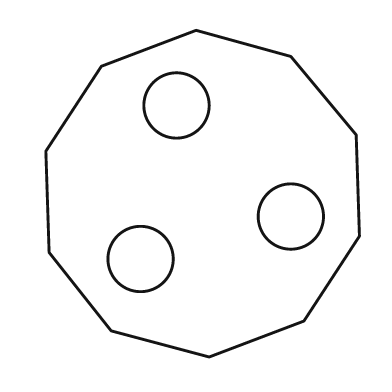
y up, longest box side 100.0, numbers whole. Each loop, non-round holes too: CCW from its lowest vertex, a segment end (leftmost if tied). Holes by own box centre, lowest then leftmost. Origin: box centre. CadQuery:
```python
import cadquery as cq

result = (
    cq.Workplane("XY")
    .moveTo(2.0, -50.0)
    .lineTo(31.0, -39.0)
    .lineTo(48.0, -13.0)
    .lineTo(47.0, 18.0)
    .lineTo(27.0, 42.0)
    .lineTo(-2.0, 50.0)
    .lineTo(-31.0, 39.0)
    .lineTo(-48.0, 13.0)
    .lineTo(-47.0, -18.0)
    .lineTo(-28.0, -42.0)
    .close()
    .moveTo(-19.0, -20.0)
    .circle(10.0)
    .moveTo(27.0, -7.0)
    .circle(10.0)
    .moveTo(-8.0, 27.0)
    .circle(10.0)
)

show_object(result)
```